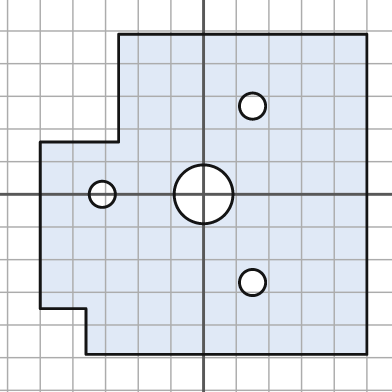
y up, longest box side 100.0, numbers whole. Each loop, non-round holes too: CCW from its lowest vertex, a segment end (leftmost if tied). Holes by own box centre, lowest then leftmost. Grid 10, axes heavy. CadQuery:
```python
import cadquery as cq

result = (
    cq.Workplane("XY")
    .moveTo(-36.0, -49.0)
    .lineTo(50.0, -49.0)
    .lineTo(50.0, 49.0)
    .lineTo(-26.0, 49.0)
    .lineTo(-26.0, 16.0)
    .lineTo(-50.0, 16.0)
    .lineTo(-50.0, -35.0)
    .lineTo(-36.0, -35.0)
    .close()
    .moveTo(15.0, -27.0)
    .circle(4.0)
    .moveTo(-31.0, 0.0)
    .circle(4.0)
    .moveTo(0.0, 0.0)
    .circle(9.0)
    .moveTo(15.0, 27.0)
    .circle(4.0)
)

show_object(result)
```